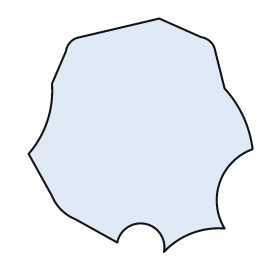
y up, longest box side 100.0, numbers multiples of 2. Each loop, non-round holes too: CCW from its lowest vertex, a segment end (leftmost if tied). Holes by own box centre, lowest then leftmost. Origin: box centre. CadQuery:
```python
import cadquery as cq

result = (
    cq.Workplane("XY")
    .moveTo(10.0, -50.0)
    .threePointArc((22.0, -42.0), (36.0, -40.0))
    .threePointArc((34.0, -20.0), (48.0, -6.0))
    .threePointArc((44.0, 8.0), (36.0, 20.0))
    .lineTo(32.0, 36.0)
    .threePointArc((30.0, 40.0), (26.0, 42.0))
    .lineTo(8.0, 50.0)
    .lineTo(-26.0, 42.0)
    .threePointArc((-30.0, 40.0), (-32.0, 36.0))
    .lineTo(-38.0, 22.0)
    .threePointArc((-40.0, 6.0), (-48.0, -8.0))
    .lineTo(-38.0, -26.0)
    .threePointArc((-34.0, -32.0), (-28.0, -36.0))
    .lineTo(-10.0, -46.0)
    .threePointArc((2.0, -38.0), (10.0, -50.0))
    .close()
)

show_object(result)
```